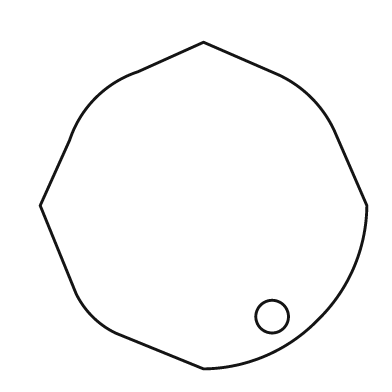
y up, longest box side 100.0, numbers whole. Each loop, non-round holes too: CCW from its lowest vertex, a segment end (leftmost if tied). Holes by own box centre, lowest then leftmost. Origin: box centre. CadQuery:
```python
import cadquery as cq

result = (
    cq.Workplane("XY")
    .moveTo(0.0, -50.0)
    .threePointArc((19.0, -46.0), (35.0, -35.0))
    .threePointArc((46.0, -19.0), (50.0, 0.0))
    .lineTo(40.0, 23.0)
    .threePointArc((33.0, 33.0), (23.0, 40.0))
    .lineTo(0.0, 50.0)
    .lineTo(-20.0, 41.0)
    .threePointArc((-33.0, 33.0), (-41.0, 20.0))
    .lineTo(-50.0, 0.0)
    .lineTo(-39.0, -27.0)
    .threePointArc((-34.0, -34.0), (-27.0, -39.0))
    .close()
    .moveTo(21.0, -34.0)
    .circle(5.0)
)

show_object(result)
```